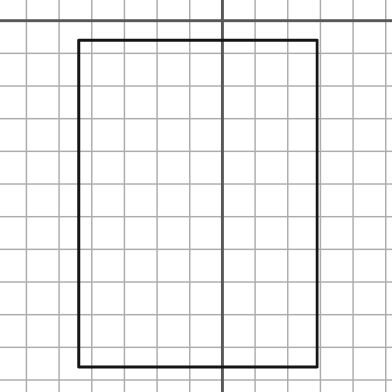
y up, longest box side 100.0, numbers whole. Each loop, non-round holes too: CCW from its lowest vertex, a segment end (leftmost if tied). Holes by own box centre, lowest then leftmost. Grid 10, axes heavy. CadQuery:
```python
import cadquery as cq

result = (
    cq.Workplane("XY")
    .moveTo(-44.0, -106.0)
    .lineTo(29.0, -106.0)
    .lineTo(29.0, -6.0)
    .lineTo(-44.0, -6.0)
    .close()
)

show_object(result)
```